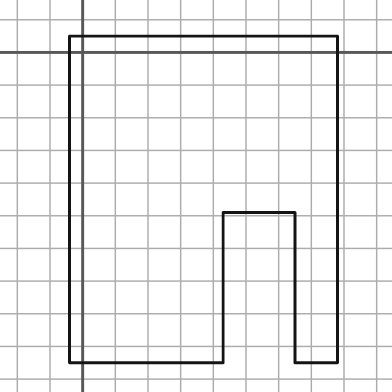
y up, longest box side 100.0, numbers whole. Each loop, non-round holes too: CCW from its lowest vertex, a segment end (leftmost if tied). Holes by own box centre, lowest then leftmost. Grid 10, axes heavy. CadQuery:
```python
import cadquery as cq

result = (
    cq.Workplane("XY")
    .moveTo(-4.0, -95.0)
    .lineTo(43.0, -95.0)
    .lineTo(43.0, -49.0)
    .lineTo(65.0, -49.0)
    .lineTo(65.0, -95.0)
    .lineTo(78.0, -95.0)
    .lineTo(78.0, 5.0)
    .lineTo(-4.0, 5.0)
    .close()
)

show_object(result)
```